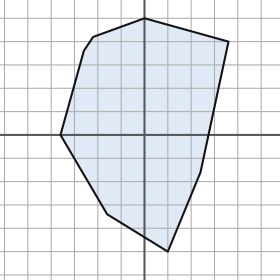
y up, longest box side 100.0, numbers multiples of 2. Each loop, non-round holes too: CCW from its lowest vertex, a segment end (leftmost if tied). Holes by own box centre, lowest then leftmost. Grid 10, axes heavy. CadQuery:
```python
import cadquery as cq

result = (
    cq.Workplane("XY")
    .moveTo(10.0, -50.0)
    .lineTo(24.0, -16.0)
    .lineTo(36.0, 40.0)
    .lineTo(0.0, 50.0)
    .lineTo(-22.0, 42.0)
    .lineTo(-26.0, 36.0)
    .lineTo(-36.0, 0.0)
    .lineTo(-16.0, -34.0)
    .close()
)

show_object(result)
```